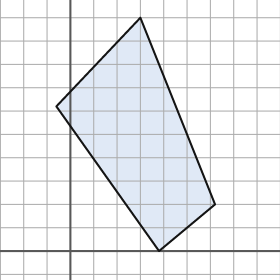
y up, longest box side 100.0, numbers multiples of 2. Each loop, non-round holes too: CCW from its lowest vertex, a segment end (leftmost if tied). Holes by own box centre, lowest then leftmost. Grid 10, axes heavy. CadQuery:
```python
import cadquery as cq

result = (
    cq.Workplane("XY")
    .moveTo(38.0, 0.0)
    .lineTo(62.0, 20.0)
    .lineTo(30.0, 100.0)
    .lineTo(-6.0, 62.0)
    .close()
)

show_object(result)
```